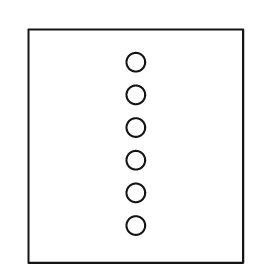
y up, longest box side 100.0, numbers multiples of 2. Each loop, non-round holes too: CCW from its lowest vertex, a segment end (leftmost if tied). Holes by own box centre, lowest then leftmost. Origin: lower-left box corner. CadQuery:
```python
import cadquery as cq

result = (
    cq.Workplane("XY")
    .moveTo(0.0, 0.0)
    .lineTo(92.0, 0.0)
    .lineTo(92.0, 100.0)
    .lineTo(0.0, 100.0)
    .close()
    .moveTo(46.0, 16.0)
    .circle(4.0)
    .moveTo(46.0, 30.0)
    .circle(4.0)
    .moveTo(46.0, 44.0)
    .circle(4.0)
    .moveTo(46.0, 58.0)
    .circle(4.0)
    .moveTo(46.0, 72.0)
    .circle(4.0)
    .moveTo(46.0, 86.0)
    .circle(4.0)
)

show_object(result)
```